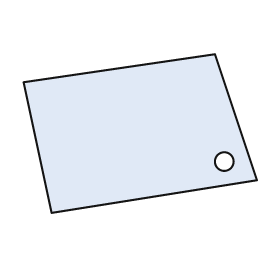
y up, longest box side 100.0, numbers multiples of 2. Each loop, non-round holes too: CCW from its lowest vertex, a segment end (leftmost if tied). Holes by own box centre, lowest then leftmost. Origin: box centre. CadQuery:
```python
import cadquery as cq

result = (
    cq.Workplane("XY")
    .moveTo(-38.0, -34.0)
    .lineTo(50.0, -20.0)
    .lineTo(32.0, 34.0)
    .lineTo(-50.0, 22.0)
    .close()
    .moveTo(36.0, -12.0)
    .circle(4.0)
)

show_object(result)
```